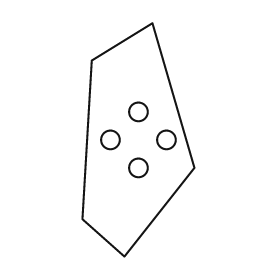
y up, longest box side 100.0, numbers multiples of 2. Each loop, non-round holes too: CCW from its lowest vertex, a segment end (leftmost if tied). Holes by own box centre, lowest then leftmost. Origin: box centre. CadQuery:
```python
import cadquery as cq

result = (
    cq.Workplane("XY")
    .moveTo(-6.0, -50.0)
    .lineTo(24.0, -12.0)
    .lineTo(6.0, 50.0)
    .lineTo(-20.0, 34.0)
    .lineTo(-24.0, -34.0)
    .close()
    .moveTo(0.0, -12.0)
    .circle(4.0)
    .moveTo(-12.0, 0.0)
    .circle(4.0)
    .moveTo(12.0, 0.0)
    .circle(4.0)
    .moveTo(0.0, 12.0)
    .circle(4.0)
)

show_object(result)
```